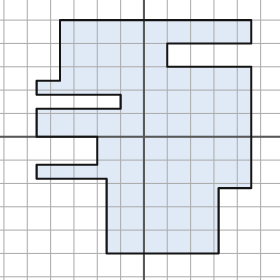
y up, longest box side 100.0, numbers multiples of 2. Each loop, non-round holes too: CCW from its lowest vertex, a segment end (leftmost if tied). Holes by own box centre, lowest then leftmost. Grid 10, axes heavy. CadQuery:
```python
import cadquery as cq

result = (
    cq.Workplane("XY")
    .moveTo(-16.0, -50.0)
    .lineTo(32.0, -50.0)
    .lineTo(32.0, -22.0)
    .lineTo(46.0, -22.0)
    .lineTo(46.0, 30.0)
    .lineTo(10.0, 30.0)
    .lineTo(10.0, 40.0)
    .lineTo(46.0, 40.0)
    .lineTo(46.0, 50.0)
    .lineTo(-36.0, 50.0)
    .lineTo(-36.0, 24.0)
    .lineTo(-46.0, 24.0)
    .lineTo(-46.0, 18.0)
    .lineTo(-10.0, 18.0)
    .lineTo(-10.0, 12.0)
    .lineTo(-46.0, 12.0)
    .lineTo(-46.0, 0.0)
    .lineTo(-20.0, 0.0)
    .lineTo(-20.0, -12.0)
    .lineTo(-46.0, -12.0)
    .lineTo(-46.0, -18.0)
    .lineTo(-16.0, -18.0)
    .close()
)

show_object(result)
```